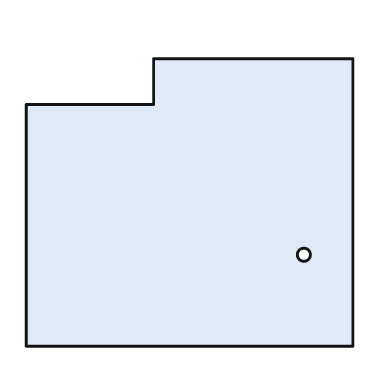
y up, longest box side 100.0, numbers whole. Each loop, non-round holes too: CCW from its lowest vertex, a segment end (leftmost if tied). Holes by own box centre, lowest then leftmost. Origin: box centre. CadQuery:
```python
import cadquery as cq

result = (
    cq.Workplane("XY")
    .moveTo(-50.0, -44.0)
    .lineTo(50.0, -44.0)
    .lineTo(50.0, 44.0)
    .lineTo(-11.0, 44.0)
    .lineTo(-11.0, 30.0)
    .lineTo(-50.0, 30.0)
    .close()
    .moveTo(35.0, -16.0)
    .circle(2.0)
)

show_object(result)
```